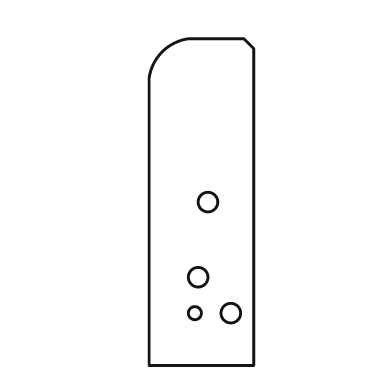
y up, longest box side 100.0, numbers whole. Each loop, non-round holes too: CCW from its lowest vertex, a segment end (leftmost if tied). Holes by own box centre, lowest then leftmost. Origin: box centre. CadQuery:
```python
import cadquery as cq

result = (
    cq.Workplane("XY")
    .moveTo(-16.0, -50.0)
    .lineTo(16.0, -50.0)
    .lineTo(16.0, 47.0)
    .lineTo(13.0, 50.0)
    .lineTo(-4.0, 50.0)
    .threePointArc((-12.0, 46.0), (-16.0, 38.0))
    .close()
    .moveTo(-2.0, -34.0)
    .circle(2.0)
    .moveTo(9.0, -34.0)
    .circle(3.0)
    .moveTo(-1.0, -23.0)
    .circle(3.0)
    .moveTo(2.0, 0.0)
    .circle(3.0)
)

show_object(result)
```